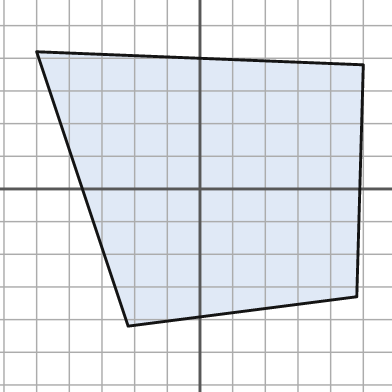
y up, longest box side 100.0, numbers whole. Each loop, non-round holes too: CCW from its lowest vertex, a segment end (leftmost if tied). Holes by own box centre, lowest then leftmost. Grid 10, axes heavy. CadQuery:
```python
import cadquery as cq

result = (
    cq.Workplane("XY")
    .moveTo(-22.0, -42.0)
    .lineTo(48.0, -33.0)
    .lineTo(50.0, 38.0)
    .lineTo(-50.0, 42.0)
    .close()
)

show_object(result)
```